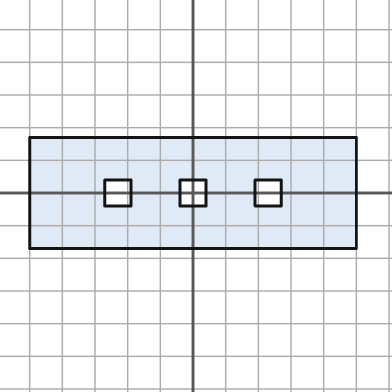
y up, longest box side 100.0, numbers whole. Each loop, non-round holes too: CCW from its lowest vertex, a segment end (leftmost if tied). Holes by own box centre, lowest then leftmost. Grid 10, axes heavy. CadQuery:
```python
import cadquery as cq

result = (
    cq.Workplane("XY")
    .moveTo(-50.0, -17.0)
    .lineTo(50.0, -17.0)
    .lineTo(50.0, 17.0)
    .lineTo(-50.0, 17.0)
    .close()
    .moveTo(-27.0, -4.0)
    .lineTo(-19.0, -4.0)
    .lineTo(-19.0, 4.0)
    .lineTo(-27.0, 4.0)
    .close()
    .moveTo(-4.0, -4.0)
    .lineTo(4.0, -4.0)
    .lineTo(4.0, 4.0)
    .lineTo(-4.0, 4.0)
    .close()
    .moveTo(19.0, -4.0)
    .lineTo(27.0, -4.0)
    .lineTo(27.0, 4.0)
    .lineTo(19.0, 4.0)
    .close()
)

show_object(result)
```